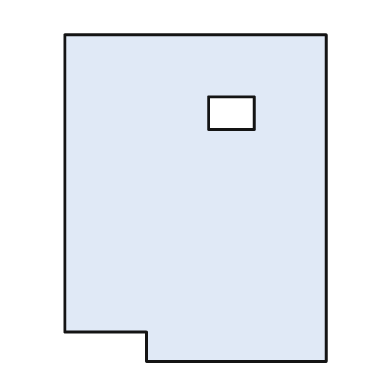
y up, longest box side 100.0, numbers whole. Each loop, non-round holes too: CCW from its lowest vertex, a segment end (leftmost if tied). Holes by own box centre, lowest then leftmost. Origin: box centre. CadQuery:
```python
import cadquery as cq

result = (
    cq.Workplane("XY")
    .moveTo(-15.0, -50.0)
    .lineTo(40.0, -50.0)
    .lineTo(40.0, 50.0)
    .lineTo(-40.0, 50.0)
    .lineTo(-40.0, -41.0)
    .lineTo(-15.0, -41.0)
    .close()
    .moveTo(4.0, 21.0)
    .lineTo(18.0, 21.0)
    .lineTo(18.0, 31.0)
    .lineTo(4.0, 31.0)
    .close()
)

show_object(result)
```